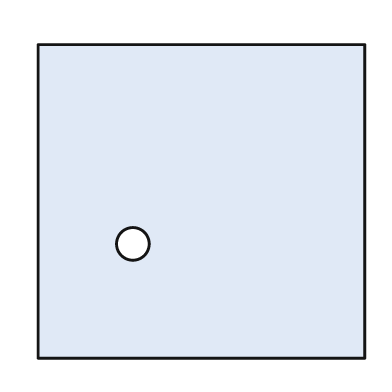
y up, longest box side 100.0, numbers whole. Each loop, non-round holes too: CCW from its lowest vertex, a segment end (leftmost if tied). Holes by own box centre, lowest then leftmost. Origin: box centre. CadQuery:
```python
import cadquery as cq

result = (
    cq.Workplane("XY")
    .moveTo(-50.0, -48.0)
    .lineTo(50.0, -48.0)
    .lineTo(50.0, 48.0)
    .lineTo(-50.0, 48.0)
    .close()
    .moveTo(-21.0, -13.0)
    .circle(5.0)
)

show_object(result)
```